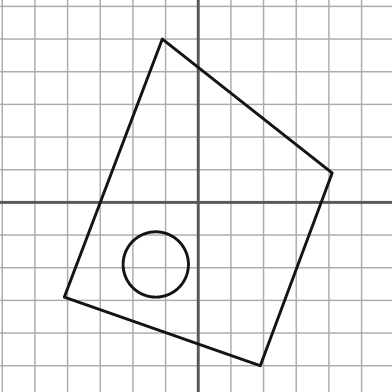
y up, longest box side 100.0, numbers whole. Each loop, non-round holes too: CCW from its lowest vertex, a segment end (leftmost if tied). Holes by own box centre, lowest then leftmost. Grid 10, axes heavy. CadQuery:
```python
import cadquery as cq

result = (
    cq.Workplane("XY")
    .moveTo(19.0, -50.0)
    .lineTo(41.0, 9.0)
    .lineTo(-11.0, 50.0)
    .lineTo(-41.0, -29.0)
    .close()
    .moveTo(-13.0, -19.0)
    .circle(10.0)
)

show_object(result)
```